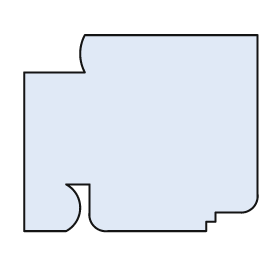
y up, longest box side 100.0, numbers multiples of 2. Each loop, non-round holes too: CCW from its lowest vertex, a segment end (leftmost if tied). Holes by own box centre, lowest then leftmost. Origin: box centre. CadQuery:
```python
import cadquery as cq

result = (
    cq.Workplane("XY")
    .moveTo(-50.0, -42.0)
    .lineTo(-32.0, -42.0)
    .threePointArc((-26.0, -32.0), (-32.0, -22.0))
    .lineTo(-22.0, -22.0)
    .lineTo(-22.0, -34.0)
    .threePointArc((-20.0, -40.0), (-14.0, -42.0))
    .lineTo(28.0, -42.0)
    .lineTo(28.0, -38.0)
    .lineTo(32.0, -38.0)
    .lineTo(32.0, -34.0)
    .lineTo(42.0, -34.0)
    .threePointArc((48.0, -32.0), (50.0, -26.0))
    .lineTo(50.0, 42.0)
    .lineTo(-24.0, 42.0)
    .threePointArc((-26.0, 34.0), (-24.0, 26.0))
    .lineTo(-50.0, 26.0)
    .close()
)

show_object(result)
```